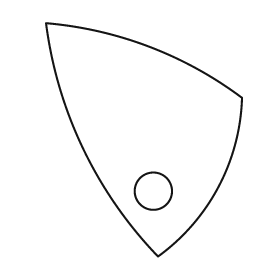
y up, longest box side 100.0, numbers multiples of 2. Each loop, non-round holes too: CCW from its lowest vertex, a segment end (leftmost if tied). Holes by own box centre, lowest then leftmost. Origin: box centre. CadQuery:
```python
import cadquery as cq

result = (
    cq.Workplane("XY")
    .moveTo(6.0, -50.0)
    .threePointArc((32.0, -20.0), (42.0, 18.0))
    .threePointArc((2.0, 40.0), (-42.0, 50.0))
    .threePointArc((-26.0, -4.0), (6.0, -50.0))
    .close()
    .moveTo(4.0, -22.0)
    .circle(8.0)
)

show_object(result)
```